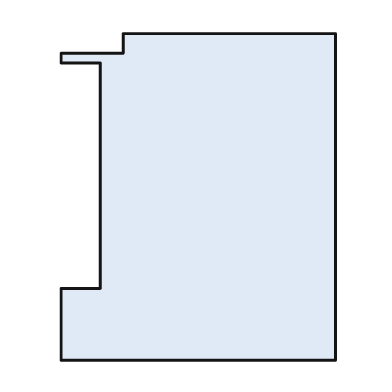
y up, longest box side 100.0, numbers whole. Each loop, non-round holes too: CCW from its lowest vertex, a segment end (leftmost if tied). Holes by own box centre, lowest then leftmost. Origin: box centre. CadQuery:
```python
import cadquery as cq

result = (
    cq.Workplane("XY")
    .moveTo(-42.0, -50.0)
    .lineTo(42.0, -50.0)
    .lineTo(42.0, 50.0)
    .lineTo(-23.0, 50.0)
    .lineTo(-23.0, 44.0)
    .lineTo(-42.0, 44.0)
    .lineTo(-42.0, 41.0)
    .lineTo(-30.0, 41.0)
    .lineTo(-30.0, -28.0)
    .lineTo(-42.0, -28.0)
    .close()
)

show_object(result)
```